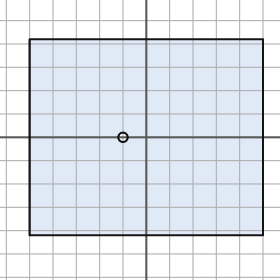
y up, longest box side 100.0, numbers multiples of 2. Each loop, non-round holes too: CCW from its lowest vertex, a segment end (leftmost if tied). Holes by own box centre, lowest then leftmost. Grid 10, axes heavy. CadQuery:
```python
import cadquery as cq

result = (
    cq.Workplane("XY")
    .moveTo(-50.0, -42.0)
    .lineTo(50.0, -42.0)
    .lineTo(50.0, 42.0)
    .lineTo(-50.0, 42.0)
    .close()
    .moveTo(-10.0, 0.0)
    .circle(2.0)
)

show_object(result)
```